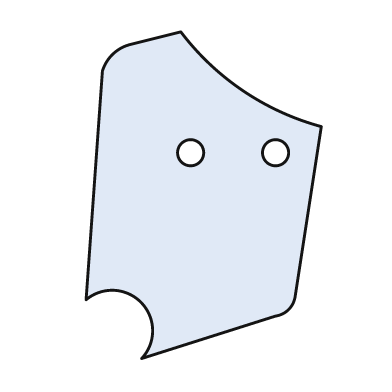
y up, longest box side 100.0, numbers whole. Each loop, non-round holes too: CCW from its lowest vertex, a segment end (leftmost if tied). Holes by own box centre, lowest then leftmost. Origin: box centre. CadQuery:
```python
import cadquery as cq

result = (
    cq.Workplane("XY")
    .moveTo(-19.0, -50.0)
    .lineTo(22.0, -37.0)
    .threePointArc((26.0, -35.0), (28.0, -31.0))
    .lineTo(36.0, 21.0)
    .threePointArc((12.0, 32.0), (-7.0, 50.0))
    .lineTo(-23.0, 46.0)
    .threePointArc((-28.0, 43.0), (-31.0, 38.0))
    .lineTo(-36.0, -32.0)
    .threePointArc((-19.0, -33.0), (-19.0, -50.0))
    .close()
    .moveTo(-4.0, 13.0)
    .circle(4.0)
    .moveTo(22.0, 13.0)
    .circle(4.0)
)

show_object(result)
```